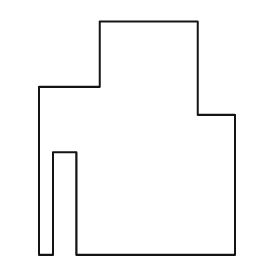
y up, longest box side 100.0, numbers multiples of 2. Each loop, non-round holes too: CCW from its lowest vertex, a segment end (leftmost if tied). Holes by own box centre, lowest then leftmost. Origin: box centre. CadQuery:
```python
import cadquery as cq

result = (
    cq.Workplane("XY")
    .moveTo(-42.0, -50.0)
    .lineTo(-36.0, -50.0)
    .lineTo(-36.0, -6.0)
    .lineTo(-26.0, -6.0)
    .lineTo(-26.0, -50.0)
    .lineTo(42.0, -50.0)
    .lineTo(42.0, 10.0)
    .lineTo(26.0, 10.0)
    .lineTo(26.0, 50.0)
    .lineTo(-16.0, 50.0)
    .lineTo(-16.0, 22.0)
    .lineTo(-42.0, 22.0)
    .close()
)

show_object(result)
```